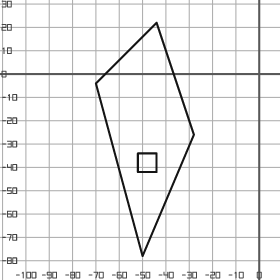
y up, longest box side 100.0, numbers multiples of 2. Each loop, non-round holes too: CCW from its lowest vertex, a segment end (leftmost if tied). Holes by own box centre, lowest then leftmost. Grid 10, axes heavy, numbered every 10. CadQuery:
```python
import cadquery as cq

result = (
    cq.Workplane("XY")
    .moveTo(-50.0, -78.0)
    .lineTo(-28.0, -26.0)
    .lineTo(-44.0, 22.0)
    .lineTo(-70.0, -4.0)
    .close()
    .moveTo(-52.0, -42.0)
    .lineTo(-44.0, -42.0)
    .lineTo(-44.0, -34.0)
    .lineTo(-52.0, -34.0)
    .close()
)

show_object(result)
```